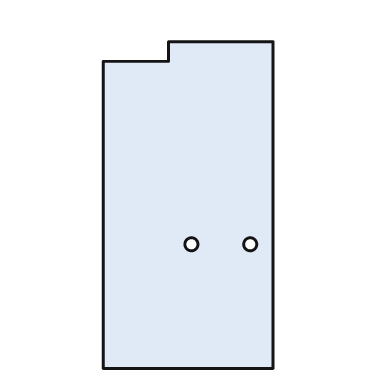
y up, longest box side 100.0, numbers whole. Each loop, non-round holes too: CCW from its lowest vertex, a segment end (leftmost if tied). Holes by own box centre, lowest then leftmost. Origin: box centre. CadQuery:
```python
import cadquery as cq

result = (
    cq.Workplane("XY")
    .moveTo(-26.0, -50.0)
    .lineTo(26.0, -50.0)
    .lineTo(26.0, 50.0)
    .lineTo(-6.0, 50.0)
    .lineTo(-6.0, 44.0)
    .lineTo(-26.0, 44.0)
    .close()
    .moveTo(1.0, -12.0)
    .circle(2.0)
    .moveTo(19.0, -12.0)
    .circle(2.0)
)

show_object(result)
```